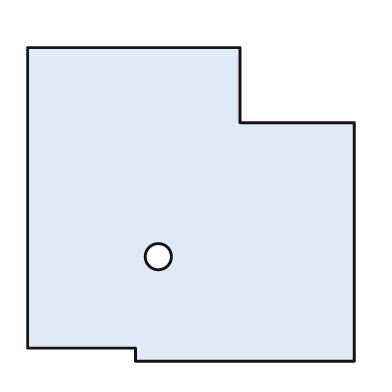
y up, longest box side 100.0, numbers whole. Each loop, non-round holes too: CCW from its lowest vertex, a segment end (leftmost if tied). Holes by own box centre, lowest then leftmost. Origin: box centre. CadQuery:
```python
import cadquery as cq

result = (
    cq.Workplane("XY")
    .moveTo(-17.0, -48.0)
    .lineTo(50.0, -48.0)
    .lineTo(50.0, 25.0)
    .lineTo(15.0, 25.0)
    .lineTo(15.0, 48.0)
    .lineTo(-50.0, 48.0)
    .lineTo(-50.0, -44.0)
    .lineTo(-17.0, -44.0)
    .close()
    .moveTo(-10.0, -16.0)
    .circle(4.0)
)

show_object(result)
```